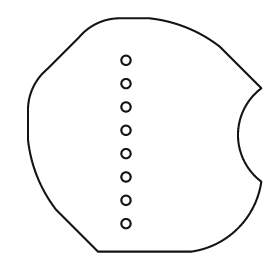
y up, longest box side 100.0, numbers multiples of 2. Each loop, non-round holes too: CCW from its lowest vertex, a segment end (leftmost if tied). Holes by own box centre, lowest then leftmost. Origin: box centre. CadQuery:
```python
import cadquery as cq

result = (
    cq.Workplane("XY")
    .moveTo(-20.0, -50.0)
    .lineTo(20.0, -50.0)
    .threePointArc((40.0, -40.0), (50.0, -20.0))
    .threePointArc((40.0, 0.0), (50.0, 20.0))
    .lineTo(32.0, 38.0)
    .threePointArc((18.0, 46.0), (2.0, 50.0))
    .lineTo(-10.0, 50.0)
    .threePointArc((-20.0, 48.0), (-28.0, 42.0))
    .lineTo(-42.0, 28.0)
    .threePointArc((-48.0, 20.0), (-50.0, 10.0))
    .lineTo(-50.0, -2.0)
    .threePointArc((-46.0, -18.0), (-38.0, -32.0))
    .close()
    .moveTo(-8.0, -38.0)
    .circle(2.0)
    .moveTo(-8.0, -28.0)
    .circle(2.0)
    .moveTo(-8.0, -18.0)
    .circle(2.0)
    .moveTo(-8.0, -8.0)
    .circle(2.0)
    .moveTo(-8.0, 2.0)
    .circle(2.0)
    .moveTo(-8.0, 12.0)
    .circle(2.0)
    .moveTo(-8.0, 22.0)
    .circle(2.0)
    .moveTo(-8.0, 32.0)
    .circle(2.0)
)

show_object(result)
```